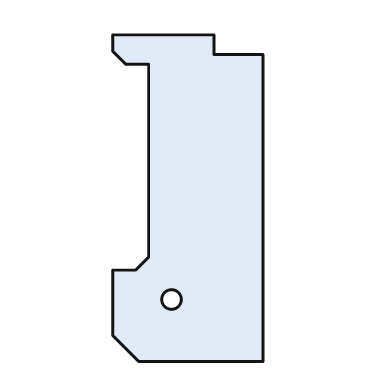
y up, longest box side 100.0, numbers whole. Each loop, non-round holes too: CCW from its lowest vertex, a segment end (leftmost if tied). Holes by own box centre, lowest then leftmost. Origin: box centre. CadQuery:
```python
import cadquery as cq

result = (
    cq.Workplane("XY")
    .moveTo(-15.0, -50.0)
    .lineTo(23.0, -50.0)
    .lineTo(23.0, 44.0)
    .lineTo(8.0, 44.0)
    .lineTo(8.0, 50.0)
    .lineTo(-23.0, 50.0)
    .lineTo(-23.0, 45.0)
    .lineTo(-19.0, 41.0)
    .lineTo(-12.0, 41.0)
    .lineTo(-12.0, -18.0)
    .lineTo(-16.0, -22.0)
    .lineTo(-23.0, -22.0)
    .lineTo(-23.0, -42.0)
    .close()
    .moveTo(-5.0, -31.0)
    .circle(3.0)
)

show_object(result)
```